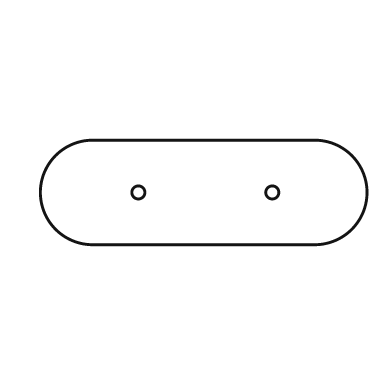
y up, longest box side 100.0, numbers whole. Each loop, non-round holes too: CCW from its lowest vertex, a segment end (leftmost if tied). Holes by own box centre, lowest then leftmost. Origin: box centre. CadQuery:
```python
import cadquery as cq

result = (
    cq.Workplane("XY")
    .moveTo(-34.0, -16.0)
    .lineTo(34.0, -16.0)
    .threePointArc((50.0, 0.0), (34.0, 16.0))
    .lineTo(-34.0, 16.0)
    .threePointArc((-50.0, 0.0), (-34.0, -16.0))
    .close()
    .moveTo(-20.0, 0.0)
    .circle(2.0)
    .moveTo(21.0, 0.0)
    .circle(2.0)
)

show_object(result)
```